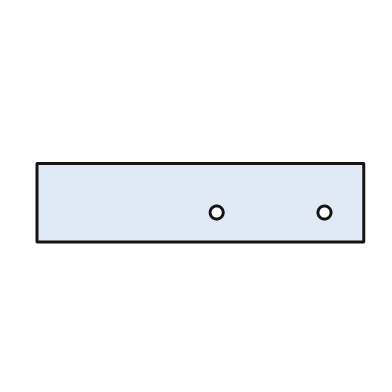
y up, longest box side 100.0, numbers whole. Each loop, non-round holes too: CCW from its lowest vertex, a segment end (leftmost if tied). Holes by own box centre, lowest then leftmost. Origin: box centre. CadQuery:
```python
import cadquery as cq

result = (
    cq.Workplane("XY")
    .moveTo(-50.0, -12.0)
    .lineTo(50.0, -12.0)
    .lineTo(50.0, 12.0)
    .lineTo(-50.0, 12.0)
    .close()
    .moveTo(5.0, -3.0)
    .circle(2.0)
    .moveTo(38.0, -3.0)
    .circle(2.0)
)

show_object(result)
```